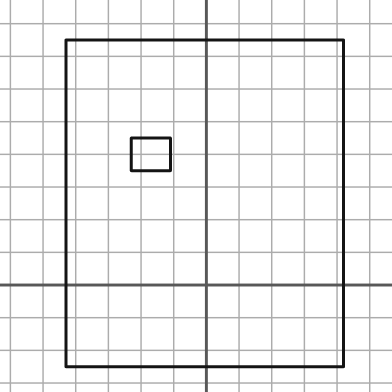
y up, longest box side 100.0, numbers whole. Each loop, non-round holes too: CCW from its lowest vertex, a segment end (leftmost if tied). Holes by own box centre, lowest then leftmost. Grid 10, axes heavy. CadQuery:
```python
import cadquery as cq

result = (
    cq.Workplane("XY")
    .moveTo(-43.0, -25.0)
    .lineTo(42.0, -25.0)
    .lineTo(42.0, 75.0)
    .lineTo(-43.0, 75.0)
    .close()
    .moveTo(-23.0, 35.0)
    .lineTo(-11.0, 35.0)
    .lineTo(-11.0, 45.0)
    .lineTo(-23.0, 45.0)
    .close()
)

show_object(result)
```